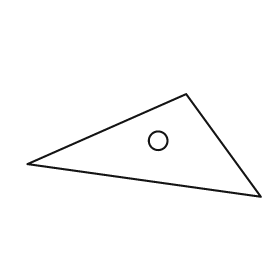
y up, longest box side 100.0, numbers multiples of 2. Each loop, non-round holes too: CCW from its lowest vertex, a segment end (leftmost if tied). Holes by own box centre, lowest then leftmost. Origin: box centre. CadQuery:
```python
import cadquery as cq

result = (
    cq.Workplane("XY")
    .moveTo(50.0, -22.0)
    .lineTo(18.0, 22.0)
    .lineTo(-50.0, -8.0)
    .close()
    .moveTo(6.0, 2.0)
    .circle(4.0)
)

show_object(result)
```